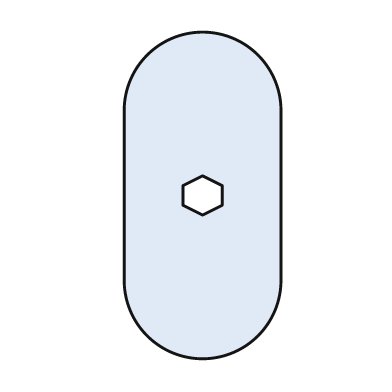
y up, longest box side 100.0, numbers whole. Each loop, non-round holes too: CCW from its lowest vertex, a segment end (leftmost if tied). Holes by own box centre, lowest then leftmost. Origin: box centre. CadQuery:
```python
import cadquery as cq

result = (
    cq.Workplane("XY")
    .moveTo(-24.0, -26.0)
    .threePointArc((0.0, -50.0), (24.0, -26.0))
    .lineTo(24.0, 26.0)
    .threePointArc((0.0, 50.0), (-24.0, 26.0))
    .close()
    .moveTo(0.0, -6.0)
    .lineTo(6.0, -3.0)
    .lineTo(6.0, 3.0)
    .lineTo(0.0, 6.0)
    .lineTo(-6.0, 3.0)
    .lineTo(-6.0, -3.0)
    .close()
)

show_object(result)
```